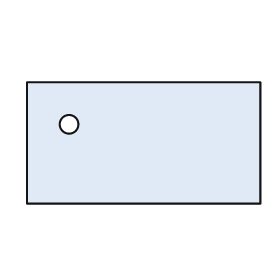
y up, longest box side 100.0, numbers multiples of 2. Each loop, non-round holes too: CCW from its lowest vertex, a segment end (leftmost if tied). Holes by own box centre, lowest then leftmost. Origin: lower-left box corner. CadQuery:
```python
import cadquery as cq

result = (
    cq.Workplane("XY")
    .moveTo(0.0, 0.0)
    .lineTo(100.0, 0.0)
    .lineTo(100.0, 52.0)
    .lineTo(0.0, 52.0)
    .close()
    .moveTo(18.0, 34.0)
    .circle(4.0)
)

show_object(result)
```